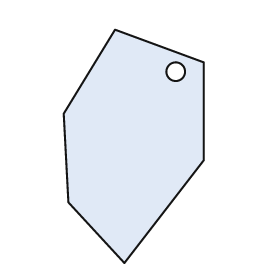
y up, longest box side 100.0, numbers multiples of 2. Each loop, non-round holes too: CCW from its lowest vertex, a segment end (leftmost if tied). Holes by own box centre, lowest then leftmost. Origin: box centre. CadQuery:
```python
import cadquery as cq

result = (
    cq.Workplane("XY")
    .moveTo(-4.0, -50.0)
    .lineTo(30.0, -6.0)
    .lineTo(30.0, 36.0)
    .lineTo(-8.0, 50.0)
    .lineTo(-30.0, 14.0)
    .lineTo(-28.0, -24.0)
    .close()
    .moveTo(18.0, 32.0)
    .circle(4.0)
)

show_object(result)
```